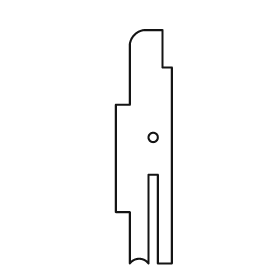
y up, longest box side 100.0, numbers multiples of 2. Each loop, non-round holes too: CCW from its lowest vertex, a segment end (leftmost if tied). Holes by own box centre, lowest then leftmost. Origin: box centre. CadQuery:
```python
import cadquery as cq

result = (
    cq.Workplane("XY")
    .moveTo(-6.0, -50.0)
    .threePointArc((-2.0, -48.0), (2.0, -50.0))
    .lineTo(2.0, -12.0)
    .lineTo(6.0, -12.0)
    .lineTo(6.0, -50.0)
    .lineTo(12.0, -50.0)
    .lineTo(12.0, 34.0)
    .lineTo(8.0, 34.0)
    .lineTo(8.0, 50.0)
    .lineTo(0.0, 50.0)
    .threePointArc((-4.0, 48.0), (-6.0, 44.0))
    .lineTo(-6.0, 18.0)
    .lineTo(-12.0, 18.0)
    .lineTo(-12.0, -28.0)
    .lineTo(-6.0, -28.0)
    .close()
    .moveTo(4.0, 4.0)
    .circle(2.0)
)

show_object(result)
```